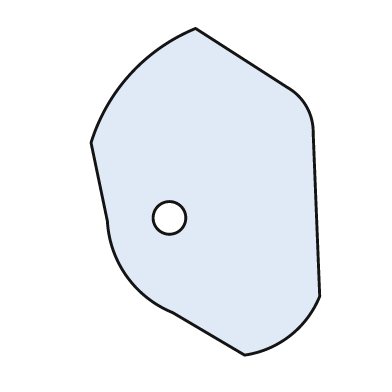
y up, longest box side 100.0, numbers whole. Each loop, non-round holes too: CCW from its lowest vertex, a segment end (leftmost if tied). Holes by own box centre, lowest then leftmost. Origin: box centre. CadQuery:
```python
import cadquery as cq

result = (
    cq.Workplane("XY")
    .moveTo(12.0, -50.0)
    .threePointArc((26.0, -44.0), (35.0, -32.0))
    .lineTo(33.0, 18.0)
    .threePointArc((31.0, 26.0), (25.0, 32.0))
    .lineTo(-3.0, 50.0)
    .threePointArc((-23.0, 36.0), (-35.0, 15.0))
    .lineTo(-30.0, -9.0)
    .threePointArc((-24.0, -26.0), (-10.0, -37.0))
    .close()
    .moveTo(-11.0, -8.0)
    .circle(5.0)
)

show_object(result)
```